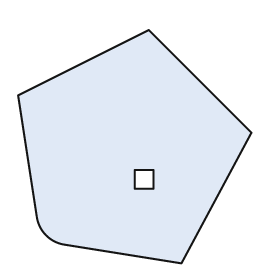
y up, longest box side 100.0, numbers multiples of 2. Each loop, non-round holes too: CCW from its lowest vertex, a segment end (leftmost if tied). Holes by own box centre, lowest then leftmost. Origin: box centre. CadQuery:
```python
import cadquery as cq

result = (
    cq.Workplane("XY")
    .moveTo(20.0, -50.0)
    .lineTo(50.0, 6.0)
    .lineTo(6.0, 50.0)
    .lineTo(-50.0, 22.0)
    .lineTo(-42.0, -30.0)
    .threePointArc((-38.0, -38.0), (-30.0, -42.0))
    .close()
    .moveTo(0.0, -18.0)
    .lineTo(8.0, -18.0)
    .lineTo(8.0, -10.0)
    .lineTo(0.0, -10.0)
    .close()
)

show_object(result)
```